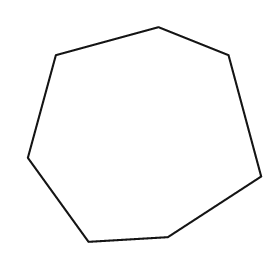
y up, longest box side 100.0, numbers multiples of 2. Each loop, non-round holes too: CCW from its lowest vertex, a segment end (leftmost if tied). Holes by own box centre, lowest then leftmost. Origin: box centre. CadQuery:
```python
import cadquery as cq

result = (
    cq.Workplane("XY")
    .moveTo(-24.0, -46.0)
    .lineTo(10.0, -44.0)
    .lineTo(50.0, -18.0)
    .lineTo(36.0, 34.0)
    .lineTo(6.0, 46.0)
    .lineTo(-38.0, 34.0)
    .lineTo(-50.0, -10.0)
    .close()
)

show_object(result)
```